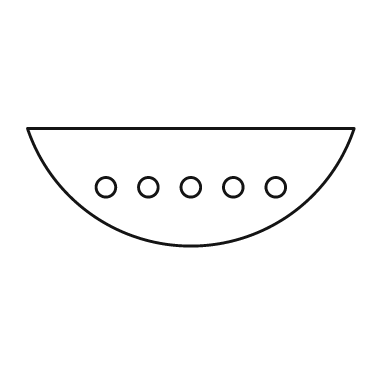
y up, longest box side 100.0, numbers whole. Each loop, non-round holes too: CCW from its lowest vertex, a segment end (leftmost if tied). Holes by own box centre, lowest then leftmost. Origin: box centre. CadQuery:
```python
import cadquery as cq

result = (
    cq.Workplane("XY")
    .moveTo(-50.0, 18.0)
    .threePointArc((0.0, -18.0), (50.0, 18.0))
    .close()
    .moveTo(-26.0, 0.0)
    .circle(3.0)
    .moveTo(-13.0, 0.0)
    .circle(3.0)
    .moveTo(0.0, 0.0)
    .circle(3.0)
    .moveTo(13.0, 0.0)
    .circle(3.0)
    .moveTo(26.0, 0.0)
    .circle(3.0)
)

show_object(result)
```